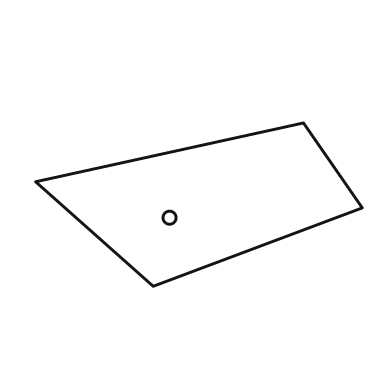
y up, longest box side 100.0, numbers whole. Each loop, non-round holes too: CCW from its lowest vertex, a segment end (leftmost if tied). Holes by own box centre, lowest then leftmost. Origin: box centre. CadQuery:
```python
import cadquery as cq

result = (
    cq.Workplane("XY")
    .moveTo(-14.0, -25.0)
    .lineTo(50.0, -1.0)
    .lineTo(32.0, 25.0)
    .lineTo(-50.0, 7.0)
    .close()
    .moveTo(-9.0, -4.0)
    .circle(2.0)
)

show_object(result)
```